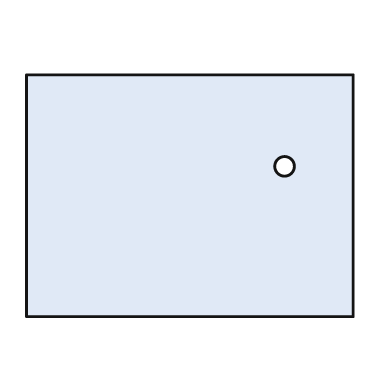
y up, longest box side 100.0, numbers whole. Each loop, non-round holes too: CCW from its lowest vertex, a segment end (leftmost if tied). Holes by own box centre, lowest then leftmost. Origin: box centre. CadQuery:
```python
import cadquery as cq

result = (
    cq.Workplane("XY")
    .moveTo(-50.0, -37.0)
    .lineTo(50.0, -37.0)
    .lineTo(50.0, 37.0)
    .lineTo(-50.0, 37.0)
    .close()
    .moveTo(29.0, 9.0)
    .circle(3.0)
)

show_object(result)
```